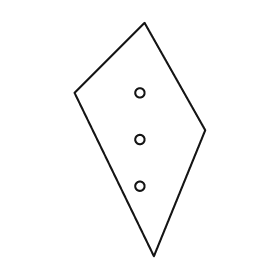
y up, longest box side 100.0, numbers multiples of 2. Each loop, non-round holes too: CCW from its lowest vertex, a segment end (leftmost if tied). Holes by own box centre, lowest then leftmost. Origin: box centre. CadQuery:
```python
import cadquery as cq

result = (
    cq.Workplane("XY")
    .moveTo(6.0, -50.0)
    .lineTo(28.0, 4.0)
    .lineTo(2.0, 50.0)
    .lineTo(-28.0, 20.0)
    .close()
    .moveTo(0.0, -20.0)
    .circle(2.0)
    .moveTo(0.0, 0.0)
    .circle(2.0)
    .moveTo(0.0, 20.0)
    .circle(2.0)
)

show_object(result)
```